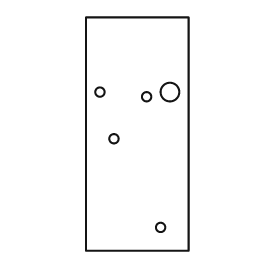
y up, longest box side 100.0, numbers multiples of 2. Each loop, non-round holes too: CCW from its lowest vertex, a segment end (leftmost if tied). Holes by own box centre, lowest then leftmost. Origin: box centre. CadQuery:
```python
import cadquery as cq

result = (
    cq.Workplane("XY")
    .moveTo(-22.0, -50.0)
    .lineTo(22.0, -50.0)
    .lineTo(22.0, 50.0)
    .lineTo(-22.0, 50.0)
    .close()
    .moveTo(10.0, -40.0)
    .circle(2.0)
    .moveTo(-10.0, -2.0)
    .circle(2.0)
    .moveTo(4.0, 16.0)
    .circle(2.0)
    .moveTo(-16.0, 18.0)
    .circle(2.0)
    .moveTo(14.0, 18.0)
    .circle(4.0)
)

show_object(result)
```